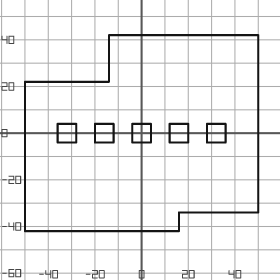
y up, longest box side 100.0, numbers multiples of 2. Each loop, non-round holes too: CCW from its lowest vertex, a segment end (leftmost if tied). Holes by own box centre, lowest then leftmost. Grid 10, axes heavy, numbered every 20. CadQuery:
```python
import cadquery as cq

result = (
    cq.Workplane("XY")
    .moveTo(-50.0, -42.0)
    .lineTo(16.0, -42.0)
    .lineTo(16.0, -34.0)
    .lineTo(50.0, -34.0)
    .lineTo(50.0, 42.0)
    .lineTo(-14.0, 42.0)
    .lineTo(-14.0, 22.0)
    .lineTo(-50.0, 22.0)
    .close()
    .moveTo(-36.0, -4.0)
    .lineTo(-28.0, -4.0)
    .lineTo(-28.0, 4.0)
    .lineTo(-36.0, 4.0)
    .close()
    .moveTo(-20.0, -4.0)
    .lineTo(-12.0, -4.0)
    .lineTo(-12.0, 4.0)
    .lineTo(-20.0, 4.0)
    .close()
    .moveTo(-4.0, -4.0)
    .lineTo(4.0, -4.0)
    .lineTo(4.0, 4.0)
    .lineTo(-4.0, 4.0)
    .close()
    .moveTo(12.0, -4.0)
    .lineTo(20.0, -4.0)
    .lineTo(20.0, 4.0)
    .lineTo(12.0, 4.0)
    .close()
    .moveTo(28.0, -4.0)
    .lineTo(36.0, -4.0)
    .lineTo(36.0, 4.0)
    .lineTo(28.0, 4.0)
    .close()
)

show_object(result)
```